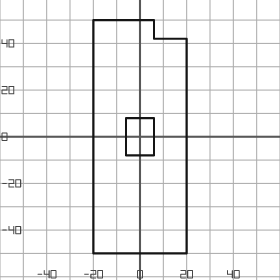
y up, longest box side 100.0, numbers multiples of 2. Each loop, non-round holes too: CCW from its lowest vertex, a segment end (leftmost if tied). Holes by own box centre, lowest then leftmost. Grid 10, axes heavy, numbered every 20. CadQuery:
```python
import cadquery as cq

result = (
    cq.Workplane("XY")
    .moveTo(-20.0, -50.0)
    .lineTo(20.0, -50.0)
    .lineTo(20.0, 42.0)
    .lineTo(6.0, 42.0)
    .lineTo(6.0, 50.0)
    .lineTo(-20.0, 50.0)
    .close()
    .moveTo(-6.0, -8.0)
    .lineTo(6.0, -8.0)
    .lineTo(6.0, 8.0)
    .lineTo(-6.0, 8.0)
    .close()
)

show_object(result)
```